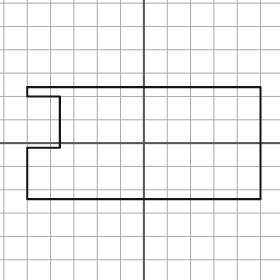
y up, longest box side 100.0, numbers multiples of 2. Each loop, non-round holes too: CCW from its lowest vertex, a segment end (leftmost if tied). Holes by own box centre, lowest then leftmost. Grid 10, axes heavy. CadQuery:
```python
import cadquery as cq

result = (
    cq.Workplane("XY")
    .moveTo(-50.0, -24.0)
    .lineTo(50.0, -24.0)
    .lineTo(50.0, 24.0)
    .lineTo(-50.0, 24.0)
    .lineTo(-50.0, 20.0)
    .lineTo(-36.0, 20.0)
    .lineTo(-36.0, -2.0)
    .lineTo(-50.0, -2.0)
    .close()
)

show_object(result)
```